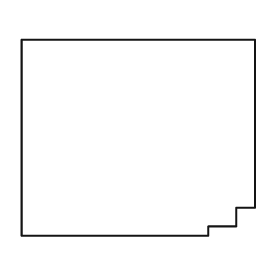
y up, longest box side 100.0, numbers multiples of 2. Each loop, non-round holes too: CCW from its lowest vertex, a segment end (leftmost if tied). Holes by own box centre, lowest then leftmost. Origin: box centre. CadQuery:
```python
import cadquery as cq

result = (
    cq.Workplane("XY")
    .moveTo(-50.0, -42.0)
    .lineTo(30.0, -42.0)
    .lineTo(30.0, -38.0)
    .lineTo(42.0, -38.0)
    .lineTo(42.0, -30.0)
    .lineTo(50.0, -30.0)
    .lineTo(50.0, 42.0)
    .lineTo(-50.0, 42.0)
    .close()
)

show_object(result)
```